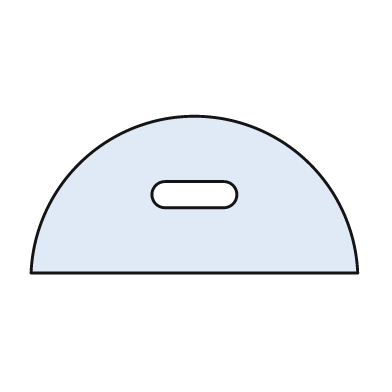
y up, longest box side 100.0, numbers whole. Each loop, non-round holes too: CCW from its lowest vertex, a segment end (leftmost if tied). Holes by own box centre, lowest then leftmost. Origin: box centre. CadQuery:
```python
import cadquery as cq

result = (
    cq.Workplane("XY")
    .moveTo(-50.0, -24.0)
    .lineTo(50.0, -24.0)
    .threePointArc((0.0, 24.0), (-50.0, -24.0))
    .close()
    .moveTo(-9.0, -4.0)
    .lineTo(9.0, -4.0)
    .threePointArc((13.0, 0.0), (9.0, 4.0))
    .lineTo(-9.0, 4.0)
    .threePointArc((-13.0, 0.0), (-9.0, -4.0))
    .close()
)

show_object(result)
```